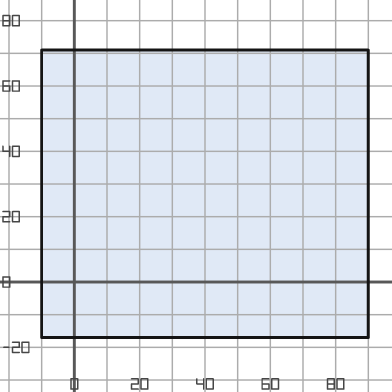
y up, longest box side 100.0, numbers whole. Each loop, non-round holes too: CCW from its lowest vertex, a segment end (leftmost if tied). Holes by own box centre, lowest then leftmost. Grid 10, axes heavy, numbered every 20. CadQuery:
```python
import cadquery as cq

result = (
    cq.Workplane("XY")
    .moveTo(-10.0, -17.0)
    .lineTo(90.0, -17.0)
    .lineTo(90.0, 71.0)
    .lineTo(-10.0, 71.0)
    .close()
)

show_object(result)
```